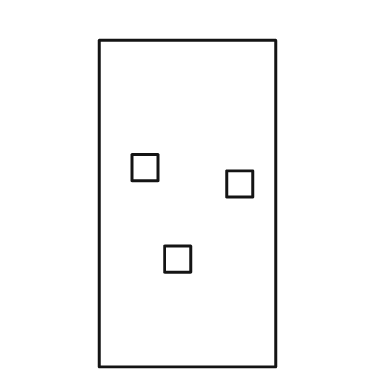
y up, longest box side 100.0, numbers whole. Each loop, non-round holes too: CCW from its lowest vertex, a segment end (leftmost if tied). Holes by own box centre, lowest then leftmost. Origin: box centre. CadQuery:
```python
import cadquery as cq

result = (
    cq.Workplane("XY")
    .moveTo(-27.0, -50.0)
    .lineTo(27.0, -50.0)
    .lineTo(27.0, 50.0)
    .lineTo(-27.0, 50.0)
    .close()
    .moveTo(-7.0, -21.0)
    .lineTo(1.0, -21.0)
    .lineTo(1.0, -13.0)
    .lineTo(-7.0, -13.0)
    .close()
    .moveTo(12.0, 2.0)
    .lineTo(20.0, 2.0)
    .lineTo(20.0, 10.0)
    .lineTo(12.0, 10.0)
    .close()
    .moveTo(-17.0, 7.0)
    .lineTo(-9.0, 7.0)
    .lineTo(-9.0, 15.0)
    .lineTo(-17.0, 15.0)
    .close()
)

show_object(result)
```